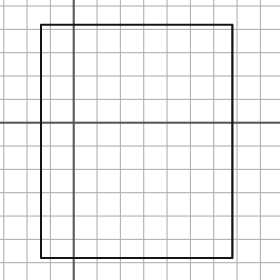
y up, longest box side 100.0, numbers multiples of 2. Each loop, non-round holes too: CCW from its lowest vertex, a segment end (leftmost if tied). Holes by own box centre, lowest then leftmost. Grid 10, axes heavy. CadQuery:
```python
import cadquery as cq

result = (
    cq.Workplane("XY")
    .moveTo(-14.0, -58.0)
    .lineTo(68.0, -58.0)
    .lineTo(68.0, 42.0)
    .lineTo(-14.0, 42.0)
    .close()
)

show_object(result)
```